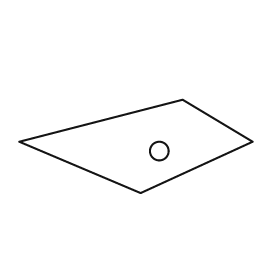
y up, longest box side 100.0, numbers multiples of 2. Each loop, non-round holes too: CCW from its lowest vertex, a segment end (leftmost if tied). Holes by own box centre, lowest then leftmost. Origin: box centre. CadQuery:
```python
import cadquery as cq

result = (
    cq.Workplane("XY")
    .moveTo(2.0, -20.0)
    .lineTo(50.0, 2.0)
    .lineTo(20.0, 20.0)
    .lineTo(-50.0, 2.0)
    .close()
    .moveTo(10.0, -2.0)
    .circle(4.0)
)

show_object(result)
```